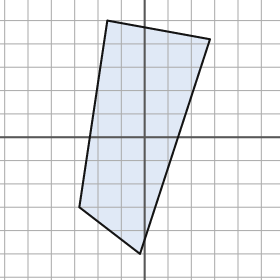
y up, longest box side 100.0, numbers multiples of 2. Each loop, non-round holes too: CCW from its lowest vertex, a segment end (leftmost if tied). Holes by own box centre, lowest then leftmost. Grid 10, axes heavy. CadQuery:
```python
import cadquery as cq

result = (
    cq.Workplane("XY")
    .moveTo(-2.0, -50.0)
    .lineTo(28.0, 42.0)
    .lineTo(-16.0, 50.0)
    .lineTo(-28.0, -30.0)
    .close()
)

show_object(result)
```